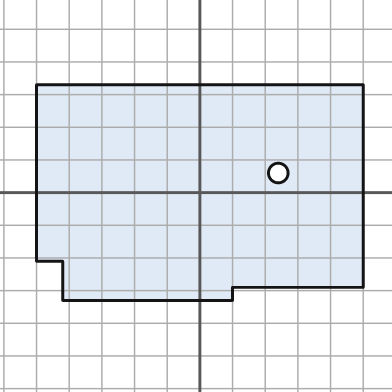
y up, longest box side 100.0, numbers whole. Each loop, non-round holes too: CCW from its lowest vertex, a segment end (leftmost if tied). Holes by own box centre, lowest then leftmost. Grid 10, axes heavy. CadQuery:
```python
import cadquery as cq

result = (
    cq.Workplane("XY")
    .moveTo(-42.0, -33.0)
    .lineTo(10.0, -33.0)
    .lineTo(10.0, -29.0)
    .lineTo(50.0, -29.0)
    .lineTo(50.0, 33.0)
    .lineTo(-50.0, 33.0)
    .lineTo(-50.0, -21.0)
    .lineTo(-42.0, -21.0)
    .close()
    .moveTo(24.0, 6.0)
    .circle(3.0)
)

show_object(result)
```